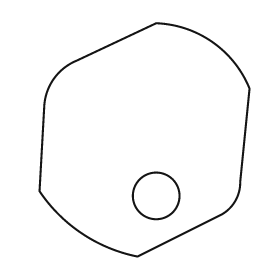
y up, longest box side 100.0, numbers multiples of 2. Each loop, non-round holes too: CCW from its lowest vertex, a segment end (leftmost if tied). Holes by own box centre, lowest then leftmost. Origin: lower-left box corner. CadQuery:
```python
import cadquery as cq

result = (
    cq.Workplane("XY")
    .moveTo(42.0, 0.0)
    .lineTo(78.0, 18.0)
    .threePointArc((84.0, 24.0), (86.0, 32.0))
    .lineTo(90.0, 72.0)
    .threePointArc((74.0, 92.0), (50.0, 100.0))
    .lineTo(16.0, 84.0)
    .threePointArc((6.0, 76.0), (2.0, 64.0))
    .lineTo(0.0, 28.0)
    .threePointArc((18.0, 10.0), (42.0, 0.0))
    .close()
    .moveTo(50.0, 26.0)
    .circle(10.0)
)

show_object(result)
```